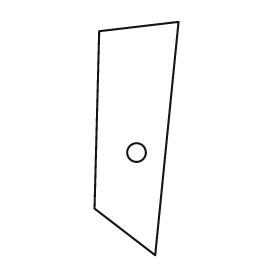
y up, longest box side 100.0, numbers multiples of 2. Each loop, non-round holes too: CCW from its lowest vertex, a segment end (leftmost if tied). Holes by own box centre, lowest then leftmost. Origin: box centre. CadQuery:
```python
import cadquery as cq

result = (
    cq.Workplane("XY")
    .moveTo(8.0, -50.0)
    .lineTo(18.0, 50.0)
    .lineTo(-16.0, 46.0)
    .lineTo(-18.0, -30.0)
    .close()
    .moveTo(0.0, -6.0)
    .circle(4.0)
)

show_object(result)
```